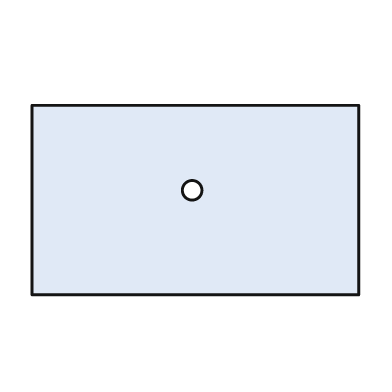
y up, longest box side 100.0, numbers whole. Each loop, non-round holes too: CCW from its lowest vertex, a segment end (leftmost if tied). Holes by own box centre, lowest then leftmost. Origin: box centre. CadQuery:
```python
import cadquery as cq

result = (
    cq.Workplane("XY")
    .moveTo(-50.0, -29.0)
    .lineTo(50.0, -29.0)
    .lineTo(50.0, 29.0)
    .lineTo(-50.0, 29.0)
    .close()
    .moveTo(-1.0, 3.0)
    .circle(3.0)
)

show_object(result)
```